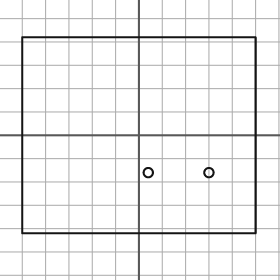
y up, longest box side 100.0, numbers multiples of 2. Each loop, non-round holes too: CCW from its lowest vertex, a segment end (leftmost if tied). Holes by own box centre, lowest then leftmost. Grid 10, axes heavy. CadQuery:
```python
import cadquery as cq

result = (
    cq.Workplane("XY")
    .moveTo(-50.0, -42.0)
    .lineTo(50.0, -42.0)
    .lineTo(50.0, 42.0)
    .lineTo(-50.0, 42.0)
    .close()
    .moveTo(4.0, -16.0)
    .circle(2.0)
    .moveTo(30.0, -16.0)
    .circle(2.0)
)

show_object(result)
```